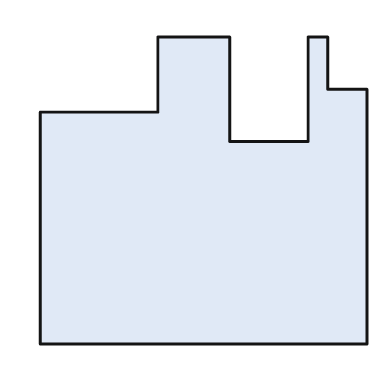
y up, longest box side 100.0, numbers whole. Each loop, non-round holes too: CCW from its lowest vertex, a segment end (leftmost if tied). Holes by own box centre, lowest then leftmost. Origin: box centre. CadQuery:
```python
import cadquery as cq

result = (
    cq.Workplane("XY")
    .moveTo(-50.0, -47.0)
    .lineTo(50.0, -47.0)
    .lineTo(50.0, 31.0)
    .lineTo(38.0, 31.0)
    .lineTo(38.0, 47.0)
    .lineTo(32.0, 47.0)
    .lineTo(32.0, 15.0)
    .lineTo(8.0, 15.0)
    .lineTo(8.0, 47.0)
    .lineTo(-14.0, 47.0)
    .lineTo(-14.0, 24.0)
    .lineTo(-50.0, 24.0)
    .close()
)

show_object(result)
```